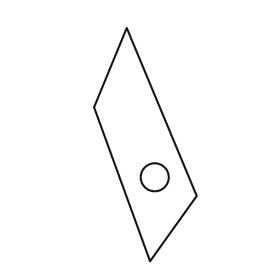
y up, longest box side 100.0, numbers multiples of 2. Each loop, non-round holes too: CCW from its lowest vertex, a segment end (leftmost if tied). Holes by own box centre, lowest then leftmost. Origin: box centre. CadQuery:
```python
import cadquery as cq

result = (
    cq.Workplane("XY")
    .moveTo(2.0, -50.0)
    .lineTo(22.0, -22.0)
    .lineTo(-8.0, 50.0)
    .lineTo(-22.0, 16.0)
    .close()
    .moveTo(4.0, -14.0)
    .circle(6.0)
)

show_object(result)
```